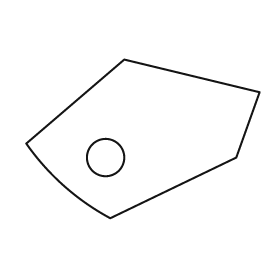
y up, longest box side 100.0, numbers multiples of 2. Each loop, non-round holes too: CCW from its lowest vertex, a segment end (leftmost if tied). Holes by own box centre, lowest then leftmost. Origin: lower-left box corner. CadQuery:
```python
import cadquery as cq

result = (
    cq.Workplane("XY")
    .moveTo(36.0, 0.0)
    .lineTo(90.0, 26.0)
    .lineTo(100.0, 54.0)
    .lineTo(42.0, 68.0)
    .lineTo(0.0, 32.0)
    .threePointArc((16.0, 14.0), (36.0, 0.0))
    .close()
    .moveTo(34.0, 26.0)
    .circle(8.0)
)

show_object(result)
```